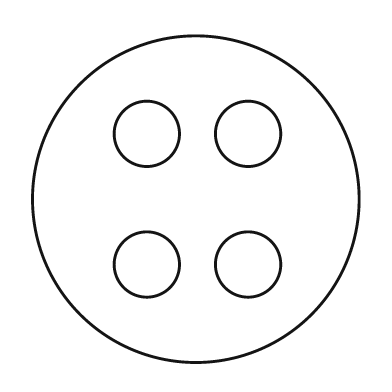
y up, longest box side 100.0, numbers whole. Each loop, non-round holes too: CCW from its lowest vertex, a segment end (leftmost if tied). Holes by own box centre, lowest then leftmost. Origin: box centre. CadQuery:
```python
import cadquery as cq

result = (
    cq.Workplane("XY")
    .moveTo(0.0, 0.0)
    .circle(50.0)
    .moveTo(-15.0, -20.0)
    .circle(10.0)
    .moveTo(16.0, -20.0)
    .circle(10.0)
    .moveTo(-15.0, 20.0)
    .circle(10.0)
    .moveTo(16.0, 20.0)
    .circle(10.0)
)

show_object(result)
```